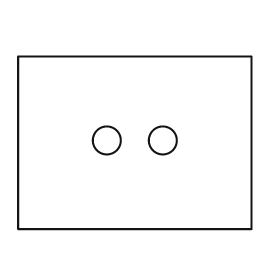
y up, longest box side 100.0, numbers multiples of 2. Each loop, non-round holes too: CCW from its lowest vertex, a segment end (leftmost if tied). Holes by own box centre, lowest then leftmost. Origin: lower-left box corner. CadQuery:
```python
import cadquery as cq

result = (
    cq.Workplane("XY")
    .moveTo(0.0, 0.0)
    .lineTo(100.0, 0.0)
    .lineTo(100.0, 74.0)
    .lineTo(0.0, 74.0)
    .close()
    .moveTo(38.0, 38.0)
    .circle(6.0)
    .moveTo(62.0, 38.0)
    .circle(6.0)
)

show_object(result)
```